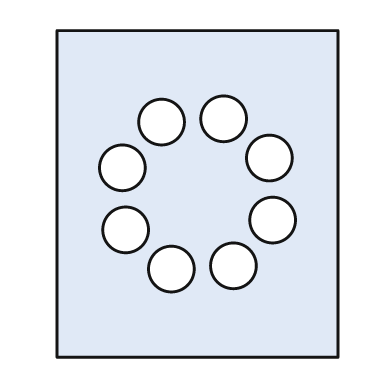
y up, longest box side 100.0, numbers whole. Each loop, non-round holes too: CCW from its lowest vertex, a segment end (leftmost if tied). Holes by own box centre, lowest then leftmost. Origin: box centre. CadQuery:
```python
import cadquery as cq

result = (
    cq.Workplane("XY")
    .moveTo(-43.0, -50.0)
    .lineTo(43.0, -50.0)
    .lineTo(43.0, 50.0)
    .lineTo(-43.0, 50.0)
    .close()
    .moveTo(-8.0, -23.0)
    .circle(7.0)
    .moveTo(11.0, -22.0)
    .circle(7.0)
    .moveTo(-22.0, -11.0)
    .circle(7.0)
    .moveTo(23.0, -8.0)
    .circle(7.0)
    .moveTo(-23.0, 8.0)
    .circle(7.0)
    .moveTo(22.0, 11.0)
    .circle(7.0)
    .moveTo(-11.0, 22.0)
    .circle(7.0)
    .moveTo(8.0, 23.0)
    .circle(7.0)
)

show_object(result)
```